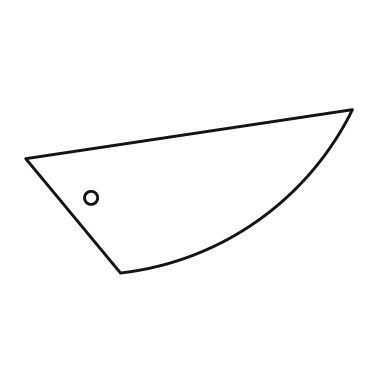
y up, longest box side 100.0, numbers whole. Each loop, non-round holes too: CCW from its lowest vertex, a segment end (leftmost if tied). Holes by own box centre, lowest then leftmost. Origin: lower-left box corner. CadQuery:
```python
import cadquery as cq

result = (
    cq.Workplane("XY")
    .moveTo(29.0, 0.0)
    .threePointArc((71.0, 16.0), (100.0, 50.0))
    .lineTo(0.0, 35.0)
    .close()
    .moveTo(20.0, 23.0)
    .circle(2.0)
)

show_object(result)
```